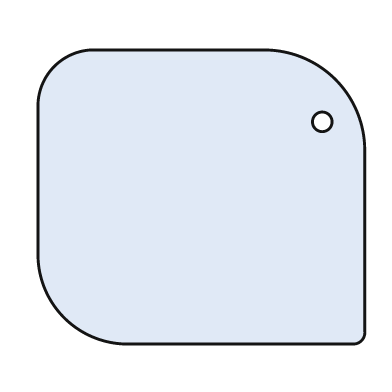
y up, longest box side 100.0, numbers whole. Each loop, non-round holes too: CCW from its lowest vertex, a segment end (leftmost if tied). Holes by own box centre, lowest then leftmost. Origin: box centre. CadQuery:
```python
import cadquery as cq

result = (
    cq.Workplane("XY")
    .moveTo(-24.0, -45.0)
    .lineTo(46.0, -45.0)
    .threePointArc((49.0, -44.0), (50.0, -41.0))
    .lineTo(50.0, 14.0)
    .threePointArc((41.0, 36.0), (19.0, 45.0))
    .lineTo(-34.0, 45.0)
    .threePointArc((-45.0, 40.0), (-50.0, 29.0))
    .lineTo(-50.0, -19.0)
    .threePointArc((-42.0, -37.0), (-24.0, -45.0))
    .close()
    .moveTo(37.0, 23.0)
    .circle(3.0)
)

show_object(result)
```